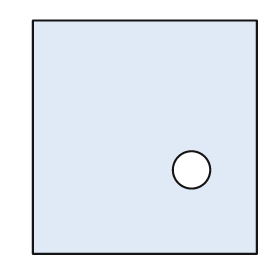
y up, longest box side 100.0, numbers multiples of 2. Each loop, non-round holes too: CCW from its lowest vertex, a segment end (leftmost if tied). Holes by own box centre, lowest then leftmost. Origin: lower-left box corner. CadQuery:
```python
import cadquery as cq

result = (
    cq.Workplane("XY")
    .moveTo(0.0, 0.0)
    .lineTo(96.0, 0.0)
    .lineTo(96.0, 100.0)
    .lineTo(0.0, 100.0)
    .close()
    .moveTo(68.0, 36.0)
    .circle(8.0)
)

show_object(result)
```